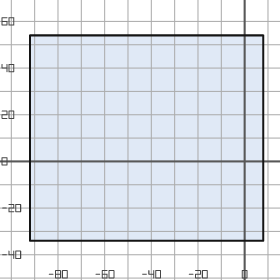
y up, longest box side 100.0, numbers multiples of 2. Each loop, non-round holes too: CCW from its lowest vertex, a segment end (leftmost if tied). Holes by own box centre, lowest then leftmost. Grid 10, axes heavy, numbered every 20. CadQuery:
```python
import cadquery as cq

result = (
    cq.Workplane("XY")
    .moveTo(-92.0, -34.0)
    .lineTo(8.0, -34.0)
    .lineTo(8.0, 54.0)
    .lineTo(-92.0, 54.0)
    .close()
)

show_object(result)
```